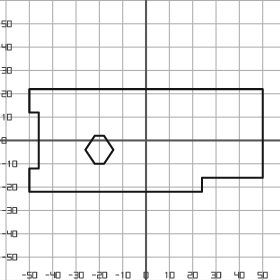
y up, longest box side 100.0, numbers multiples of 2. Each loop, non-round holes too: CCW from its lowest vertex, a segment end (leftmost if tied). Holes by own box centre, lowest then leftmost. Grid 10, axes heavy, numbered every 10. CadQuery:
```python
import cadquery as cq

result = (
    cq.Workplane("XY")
    .moveTo(-50.0, -22.0)
    .lineTo(24.0, -22.0)
    .lineTo(24.0, -16.0)
    .lineTo(50.0, -16.0)
    .lineTo(50.0, 22.0)
    .lineTo(-50.0, 22.0)
    .lineTo(-50.0, 12.0)
    .lineTo(-46.0, 12.0)
    .lineTo(-46.0, -12.0)
    .lineTo(-50.0, -12.0)
    .close()
    .moveTo(-22.0, -10.0)
    .lineTo(-18.0, -10.0)
    .lineTo(-14.0, -4.0)
    .lineTo(-18.0, 2.0)
    .lineTo(-22.0, 2.0)
    .lineTo(-26.0, -4.0)
    .close()
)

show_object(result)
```